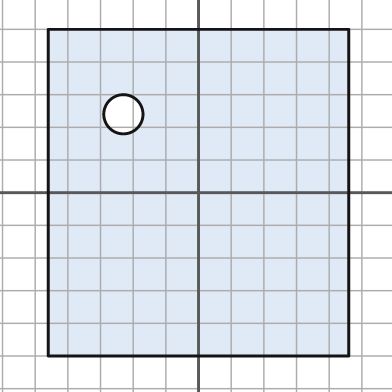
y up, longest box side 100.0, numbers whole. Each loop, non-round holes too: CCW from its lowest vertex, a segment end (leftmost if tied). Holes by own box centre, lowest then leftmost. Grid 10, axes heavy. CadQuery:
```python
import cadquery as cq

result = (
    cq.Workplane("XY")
    .moveTo(-46.0, -50.0)
    .lineTo(46.0, -50.0)
    .lineTo(46.0, 50.0)
    .lineTo(-46.0, 50.0)
    .close()
    .moveTo(-23.0, 24.0)
    .circle(6.0)
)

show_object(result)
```